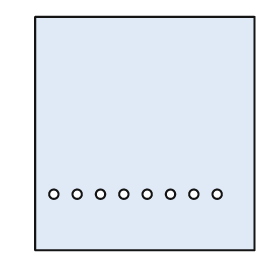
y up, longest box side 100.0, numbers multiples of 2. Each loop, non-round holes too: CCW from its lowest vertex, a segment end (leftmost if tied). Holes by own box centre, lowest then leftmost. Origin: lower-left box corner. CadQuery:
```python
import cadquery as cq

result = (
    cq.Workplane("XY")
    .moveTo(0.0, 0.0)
    .lineTo(94.0, 0.0)
    .lineTo(94.0, 100.0)
    .lineTo(0.0, 100.0)
    .close()
    .moveTo(8.0, 24.0)
    .circle(2.0)
    .moveTo(18.0, 24.0)
    .circle(2.0)
    .moveTo(28.0, 24.0)
    .circle(2.0)
    .moveTo(38.0, 24.0)
    .circle(2.0)
    .moveTo(48.0, 24.0)
    .circle(2.0)
    .moveTo(58.0, 24.0)
    .circle(2.0)
    .moveTo(68.0, 24.0)
    .circle(2.0)
    .moveTo(78.0, 24.0)
    .circle(2.0)
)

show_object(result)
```